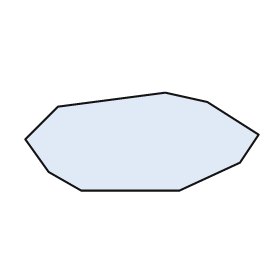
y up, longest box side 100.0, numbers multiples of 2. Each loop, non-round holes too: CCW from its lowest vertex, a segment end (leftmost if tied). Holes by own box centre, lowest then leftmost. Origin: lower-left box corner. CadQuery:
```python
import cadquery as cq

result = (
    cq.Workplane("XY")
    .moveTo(24.0, 0.0)
    .lineTo(66.0, 0.0)
    .lineTo(92.0, 12.0)
    .lineTo(100.0, 24.0)
    .lineTo(78.0, 38.0)
    .lineTo(60.0, 42.0)
    .lineTo(14.0, 36.0)
    .lineTo(0.0, 22.0)
    .lineTo(10.0, 8.0)
    .close()
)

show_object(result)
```